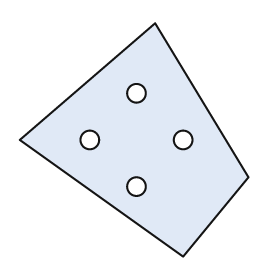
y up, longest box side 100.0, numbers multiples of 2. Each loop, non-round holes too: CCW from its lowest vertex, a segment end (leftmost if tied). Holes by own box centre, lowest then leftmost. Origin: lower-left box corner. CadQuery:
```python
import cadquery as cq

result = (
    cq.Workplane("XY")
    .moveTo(70.0, 0.0)
    .lineTo(98.0, 34.0)
    .lineTo(58.0, 100.0)
    .lineTo(0.0, 50.0)
    .close()
    .moveTo(50.0, 30.0)
    .circle(4.0)
    .moveTo(30.0, 50.0)
    .circle(4.0)
    .moveTo(70.0, 50.0)
    .circle(4.0)
    .moveTo(50.0, 70.0)
    .circle(4.0)
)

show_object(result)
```